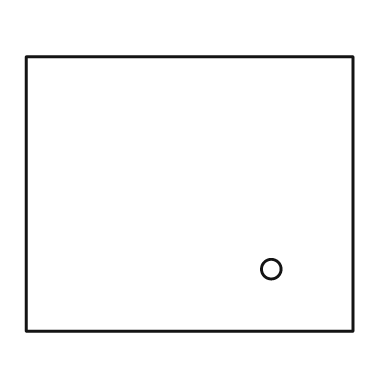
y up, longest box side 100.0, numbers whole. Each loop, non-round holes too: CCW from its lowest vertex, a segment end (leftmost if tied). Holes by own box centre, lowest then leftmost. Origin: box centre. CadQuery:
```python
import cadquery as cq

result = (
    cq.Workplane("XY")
    .moveTo(-50.0, -42.0)
    .lineTo(50.0, -42.0)
    .lineTo(50.0, 42.0)
    .lineTo(-50.0, 42.0)
    .close()
    .moveTo(25.0, -23.0)
    .circle(3.0)
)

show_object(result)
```